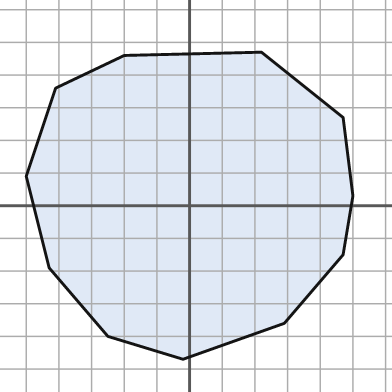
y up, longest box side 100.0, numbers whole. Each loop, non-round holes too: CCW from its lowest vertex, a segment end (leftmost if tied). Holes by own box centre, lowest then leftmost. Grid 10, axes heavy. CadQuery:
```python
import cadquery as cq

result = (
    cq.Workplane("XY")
    .moveTo(-2.0, -47.0)
    .lineTo(29.0, -36.0)
    .lineTo(47.0, -15.0)
    .lineTo(50.0, 3.0)
    .lineTo(47.0, 27.0)
    .lineTo(22.0, 47.0)
    .lineTo(-20.0, 46.0)
    .lineTo(-41.0, 36.0)
    .lineTo(-50.0, 9.0)
    .lineTo(-43.0, -19.0)
    .lineTo(-25.0, -40.0)
    .close()
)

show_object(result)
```